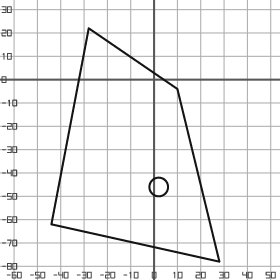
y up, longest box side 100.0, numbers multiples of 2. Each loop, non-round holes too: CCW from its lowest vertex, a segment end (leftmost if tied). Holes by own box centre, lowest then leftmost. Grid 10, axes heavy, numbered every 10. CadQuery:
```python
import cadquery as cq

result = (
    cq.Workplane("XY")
    .moveTo(28.0, -78.0)
    .lineTo(10.0, -4.0)
    .lineTo(-28.0, 22.0)
    .lineTo(-44.0, -62.0)
    .close()
    .moveTo(2.0, -46.0)
    .circle(4.0)
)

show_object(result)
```